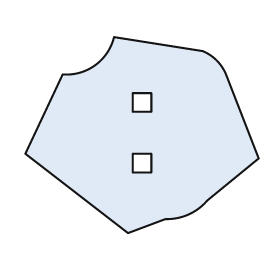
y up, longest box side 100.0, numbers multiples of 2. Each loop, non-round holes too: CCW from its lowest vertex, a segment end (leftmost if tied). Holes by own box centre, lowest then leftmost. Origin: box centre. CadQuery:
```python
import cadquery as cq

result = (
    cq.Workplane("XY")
    .moveTo(-6.0, -42.0)
    .lineTo(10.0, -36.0)
    .threePointArc((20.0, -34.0), (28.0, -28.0))
    .lineTo(50.0, -10.0)
    .lineTo(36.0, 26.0)
    .threePointArc((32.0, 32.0), (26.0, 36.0))
    .lineTo(-12.0, 42.0)
    .threePointArc((-20.0, 30.0), (-34.0, 26.0))
    .lineTo(-50.0, -8.0)
    .close()
    .moveTo(-4.0, -16.0)
    .lineTo(4.0, -16.0)
    .lineTo(4.0, -8.0)
    .lineTo(-4.0, -8.0)
    .close()
    .moveTo(-4.0, 10.0)
    .lineTo(4.0, 10.0)
    .lineTo(4.0, 18.0)
    .lineTo(-4.0, 18.0)
    .close()
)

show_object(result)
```